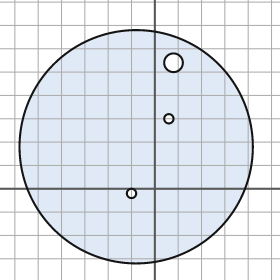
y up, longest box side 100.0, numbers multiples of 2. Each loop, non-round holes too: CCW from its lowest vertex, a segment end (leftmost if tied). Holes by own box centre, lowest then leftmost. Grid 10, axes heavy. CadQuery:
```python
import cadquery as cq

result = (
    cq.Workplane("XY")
    .moveTo(-8.0, 18.0)
    .circle(50.0)
    .moveTo(-10.0, -2.0)
    .circle(2.0)
    .moveTo(6.0, 30.0)
    .circle(2.0)
    .moveTo(8.0, 54.0)
    .circle(4.0)
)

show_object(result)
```